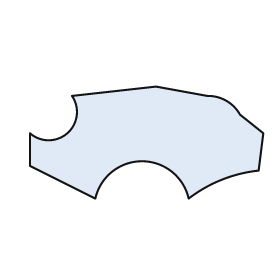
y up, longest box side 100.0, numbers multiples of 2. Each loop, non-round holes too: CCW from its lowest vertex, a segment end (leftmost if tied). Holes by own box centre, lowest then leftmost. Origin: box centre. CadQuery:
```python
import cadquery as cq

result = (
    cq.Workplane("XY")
    .moveTo(-22.0, -24.0)
    .threePointArc((-2.0, -8.0), (18.0, -24.0))
    .threePointArc((32.0, -16.0), (48.0, -12.0))
    .lineTo(50.0, 4.0)
    .lineTo(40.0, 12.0)
    .threePointArc((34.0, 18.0), (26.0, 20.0))
    .lineTo(4.0, 24.0)
    .lineTo(-32.0, 20.0)
    .threePointArc((-34.0, 4.0), (-50.0, 4.0))
    .lineTo(-50.0, -10.0)
    .close()
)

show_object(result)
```